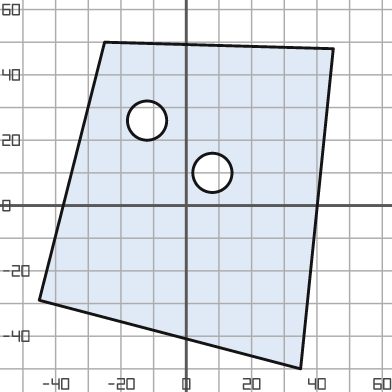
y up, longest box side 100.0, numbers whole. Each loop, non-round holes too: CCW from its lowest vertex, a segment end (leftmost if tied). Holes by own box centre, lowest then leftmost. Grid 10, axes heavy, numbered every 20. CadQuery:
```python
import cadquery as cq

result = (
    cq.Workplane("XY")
    .moveTo(35.0, -50.0)
    .lineTo(45.0, 48.0)
    .lineTo(-25.0, 50.0)
    .lineTo(-45.0, -29.0)
    .close()
    .moveTo(8.0, 10.0)
    .circle(6.0)
    .moveTo(-12.0, 26.0)
    .circle(6.0)
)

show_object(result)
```